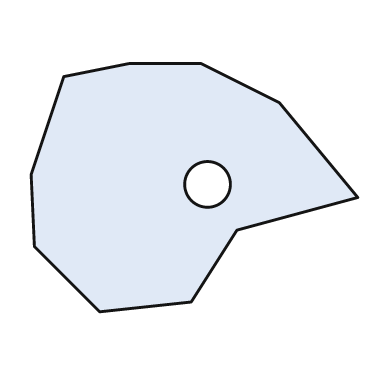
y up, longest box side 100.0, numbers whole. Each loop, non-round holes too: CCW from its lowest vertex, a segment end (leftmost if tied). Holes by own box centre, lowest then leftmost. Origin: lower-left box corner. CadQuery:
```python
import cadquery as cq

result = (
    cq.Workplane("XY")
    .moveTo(21.0, 0.0)
    .lineTo(49.0, 3.0)
    .lineTo(63.0, 25.0)
    .lineTo(100.0, 35.0)
    .lineTo(76.0, 64.0)
    .lineTo(52.0, 76.0)
    .lineTo(30.0, 76.0)
    .lineTo(10.0, 72.0)
    .lineTo(0.0, 42.0)
    .lineTo(1.0, 20.0)
    .close()
    .moveTo(54.0, 39.0)
    .circle(7.0)
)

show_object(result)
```